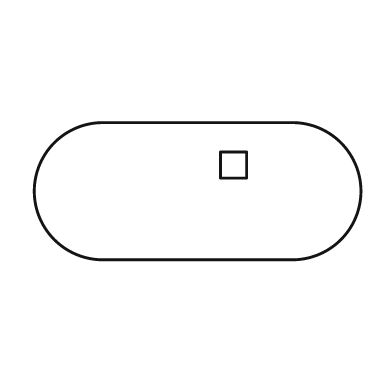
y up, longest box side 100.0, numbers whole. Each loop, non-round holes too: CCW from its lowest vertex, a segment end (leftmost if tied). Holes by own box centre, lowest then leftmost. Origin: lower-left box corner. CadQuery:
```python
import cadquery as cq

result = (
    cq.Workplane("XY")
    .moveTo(21.0, 0.0)
    .lineTo(79.0, 0.0)
    .threePointArc((100.0, 21.0), (79.0, 42.0))
    .lineTo(21.0, 42.0)
    .threePointArc((0.0, 21.0), (21.0, 0.0))
    .close()
    .moveTo(57.0, 25.0)
    .lineTo(65.0, 25.0)
    .lineTo(65.0, 33.0)
    .lineTo(57.0, 33.0)
    .close()
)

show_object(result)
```